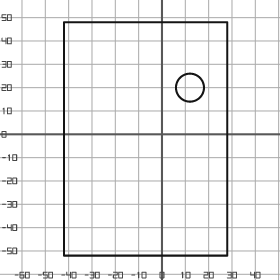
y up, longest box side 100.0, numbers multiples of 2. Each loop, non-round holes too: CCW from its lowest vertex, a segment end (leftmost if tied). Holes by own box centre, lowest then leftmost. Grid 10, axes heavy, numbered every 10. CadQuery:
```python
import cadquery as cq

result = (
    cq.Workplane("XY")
    .moveTo(-42.0, -52.0)
    .lineTo(28.0, -52.0)
    .lineTo(28.0, 48.0)
    .lineTo(-42.0, 48.0)
    .close()
    .moveTo(12.0, 20.0)
    .circle(6.0)
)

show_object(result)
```